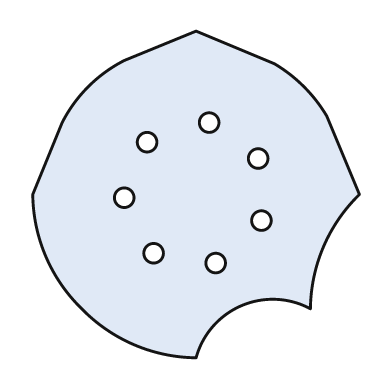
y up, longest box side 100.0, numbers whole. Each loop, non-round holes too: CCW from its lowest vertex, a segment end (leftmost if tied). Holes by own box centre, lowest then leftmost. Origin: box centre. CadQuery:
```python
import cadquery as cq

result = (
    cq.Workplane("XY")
    .moveTo(0.0, -50.0)
    .threePointArc((14.0, -34.0), (35.0, -35.0))
    .threePointArc((39.0, -16.0), (50.0, 0.0))
    .lineTo(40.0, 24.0)
    .threePointArc((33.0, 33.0), (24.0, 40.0))
    .lineTo(0.0, 50.0)
    .lineTo(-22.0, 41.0)
    .threePointArc((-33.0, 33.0), (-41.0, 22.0))
    .lineTo(-50.0, 0.0)
    .threePointArc((-46.0, -19.0), (-35.0, -35.0))
    .threePointArc((-19.0, -46.0), (0.0, -50.0))
    .close()
    .moveTo(6.0, -21.0)
    .circle(3.0)
    .moveTo(-13.0, -18.0)
    .circle(3.0)
    .moveTo(20.0, -8.0)
    .circle(3.0)
    .moveTo(-22.0, -1.0)
    .circle(3.0)
    .moveTo(19.0, 11.0)
    .circle(3.0)
    .moveTo(-15.0, 16.0)
    .circle(3.0)
    .moveTo(4.0, 22.0)
    .circle(3.0)
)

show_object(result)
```